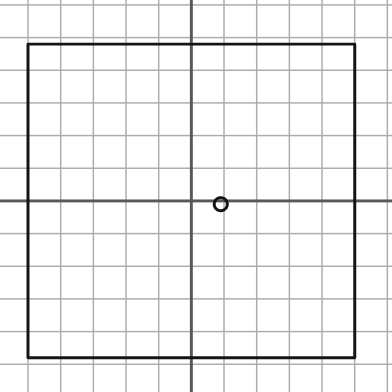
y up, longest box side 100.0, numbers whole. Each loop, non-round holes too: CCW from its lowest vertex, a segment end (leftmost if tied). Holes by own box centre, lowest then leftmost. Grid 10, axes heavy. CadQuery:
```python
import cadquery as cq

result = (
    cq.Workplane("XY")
    .moveTo(-50.0, -48.0)
    .lineTo(50.0, -48.0)
    .lineTo(50.0, 48.0)
    .lineTo(-50.0, 48.0)
    .close()
    .moveTo(9.0, -1.0)
    .circle(2.0)
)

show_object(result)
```